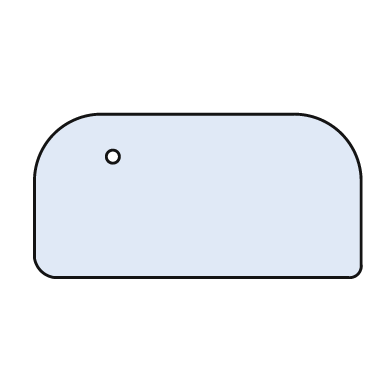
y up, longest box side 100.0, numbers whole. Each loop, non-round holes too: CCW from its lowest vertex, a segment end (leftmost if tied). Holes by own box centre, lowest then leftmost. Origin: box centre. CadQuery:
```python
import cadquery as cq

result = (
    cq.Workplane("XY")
    .moveTo(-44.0, -25.0)
    .lineTo(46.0, -25.0)
    .threePointArc((49.0, -24.0), (50.0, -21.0))
    .lineTo(50.0, 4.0)
    .threePointArc((44.0, 19.0), (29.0, 25.0))
    .lineTo(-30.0, 25.0)
    .threePointArc((-44.0, 19.0), (-50.0, 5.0))
    .lineTo(-50.0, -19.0)
    .threePointArc((-48.0, -23.0), (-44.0, -25.0))
    .close()
    .moveTo(-26.0, 12.0)
    .circle(2.0)
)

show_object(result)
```